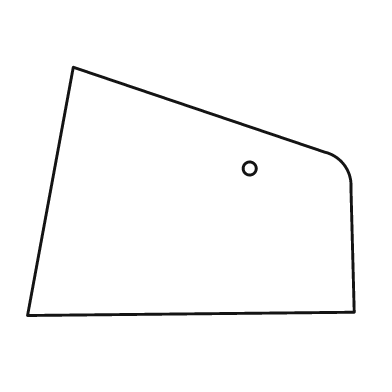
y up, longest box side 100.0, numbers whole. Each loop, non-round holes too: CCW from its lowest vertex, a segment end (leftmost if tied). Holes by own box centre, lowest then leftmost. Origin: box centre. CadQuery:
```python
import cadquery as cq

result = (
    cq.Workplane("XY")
    .moveTo(-50.0, -38.0)
    .lineTo(50.0, -37.0)
    .lineTo(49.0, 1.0)
    .threePointArc((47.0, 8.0), (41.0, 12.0))
    .lineTo(-36.0, 38.0)
    .close()
    .moveTo(18.0, 7.0)
    .circle(2.0)
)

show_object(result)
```